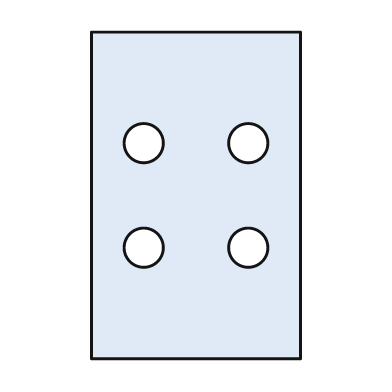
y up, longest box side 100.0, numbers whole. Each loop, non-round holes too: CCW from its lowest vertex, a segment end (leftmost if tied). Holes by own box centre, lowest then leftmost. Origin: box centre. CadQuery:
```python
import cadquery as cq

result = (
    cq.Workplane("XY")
    .moveTo(-32.0, -50.0)
    .lineTo(32.0, -50.0)
    .lineTo(32.0, 50.0)
    .lineTo(-32.0, 50.0)
    .close()
    .moveTo(-16.0, -16.0)
    .circle(6.0)
    .moveTo(16.0, -16.0)
    .circle(6.0)
    .moveTo(-16.0, 16.0)
    .circle(6.0)
    .moveTo(16.0, 16.0)
    .circle(6.0)
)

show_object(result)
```